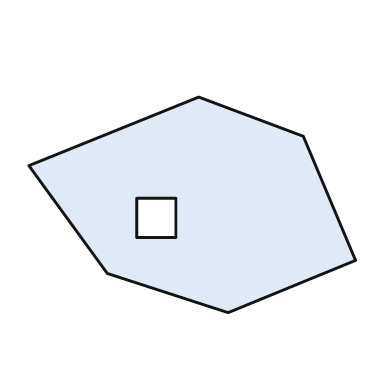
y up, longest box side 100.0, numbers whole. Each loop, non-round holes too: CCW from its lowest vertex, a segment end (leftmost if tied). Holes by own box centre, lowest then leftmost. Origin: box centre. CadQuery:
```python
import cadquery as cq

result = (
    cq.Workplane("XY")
    .moveTo(11.0, -33.0)
    .lineTo(50.0, -17.0)
    .lineTo(34.0, 21.0)
    .lineTo(2.0, 33.0)
    .lineTo(-50.0, 12.0)
    .lineTo(-26.0, -21.0)
    .close()
    .moveTo(-17.0, -10.0)
    .lineTo(-5.0, -10.0)
    .lineTo(-5.0, 2.0)
    .lineTo(-17.0, 2.0)
    .close()
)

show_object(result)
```